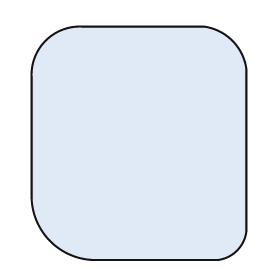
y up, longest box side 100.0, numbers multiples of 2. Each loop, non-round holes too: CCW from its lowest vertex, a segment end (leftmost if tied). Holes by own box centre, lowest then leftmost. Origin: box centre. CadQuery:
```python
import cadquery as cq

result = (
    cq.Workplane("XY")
    .moveTo(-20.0, -50.0)
    .lineTo(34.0, -50.0)
    .threePointArc((42.0, -46.0), (46.0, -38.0))
    .lineTo(46.0, 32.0)
    .threePointArc((40.0, 44.0), (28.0, 50.0))
    .lineTo(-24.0, 50.0)
    .threePointArc((-40.0, 44.0), (-46.0, 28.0))
    .lineTo(-46.0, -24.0)
    .threePointArc((-38.0, -42.0), (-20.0, -50.0))
    .close()
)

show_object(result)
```